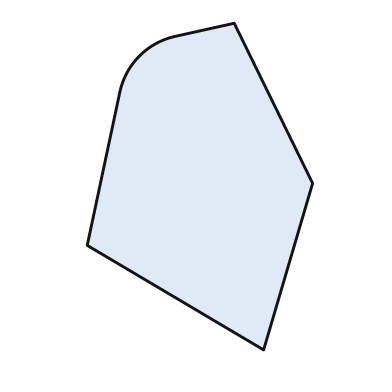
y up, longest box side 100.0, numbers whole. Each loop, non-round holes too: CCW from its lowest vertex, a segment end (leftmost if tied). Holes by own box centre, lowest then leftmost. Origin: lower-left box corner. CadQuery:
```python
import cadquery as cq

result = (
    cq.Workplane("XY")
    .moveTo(54.0, 0.0)
    .lineTo(69.0, 51.0)
    .lineTo(45.0, 100.0)
    .lineTo(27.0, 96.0)
    .threePointArc((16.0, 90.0), (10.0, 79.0))
    .lineTo(0.0, 32.0)
    .close()
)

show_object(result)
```